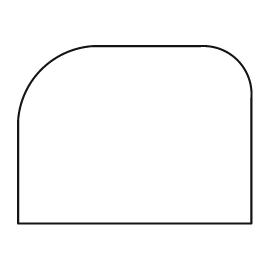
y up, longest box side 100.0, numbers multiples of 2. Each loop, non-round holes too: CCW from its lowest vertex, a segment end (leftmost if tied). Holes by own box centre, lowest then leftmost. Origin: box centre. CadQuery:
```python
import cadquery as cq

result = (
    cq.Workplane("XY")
    .moveTo(-50.0, -38.0)
    .lineTo(50.0, -38.0)
    .lineTo(50.0, 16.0)
    .threePointArc((44.0, 32.0), (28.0, 38.0))
    .lineTo(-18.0, 38.0)
    .threePointArc((-40.0, 28.0), (-50.0, 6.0))
    .close()
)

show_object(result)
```